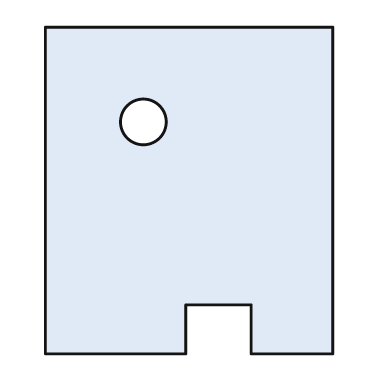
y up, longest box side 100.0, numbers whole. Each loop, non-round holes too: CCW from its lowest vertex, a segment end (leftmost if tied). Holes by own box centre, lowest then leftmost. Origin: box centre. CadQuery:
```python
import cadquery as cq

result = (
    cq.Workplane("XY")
    .moveTo(-44.0, -50.0)
    .lineTo(-1.0, -50.0)
    .lineTo(-1.0, -35.0)
    .lineTo(19.0, -35.0)
    .lineTo(19.0, -50.0)
    .lineTo(44.0, -50.0)
    .lineTo(44.0, 50.0)
    .lineTo(-44.0, 50.0)
    .close()
    .moveTo(-14.0, 21.0)
    .circle(7.0)
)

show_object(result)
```